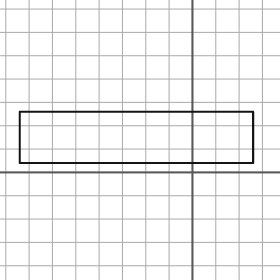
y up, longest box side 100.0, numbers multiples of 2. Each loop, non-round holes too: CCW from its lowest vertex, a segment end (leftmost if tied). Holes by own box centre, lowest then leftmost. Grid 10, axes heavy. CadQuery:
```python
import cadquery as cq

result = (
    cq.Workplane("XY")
    .moveTo(-74.0, 4.0)
    .lineTo(26.0, 4.0)
    .lineTo(26.0, 26.0)
    .lineTo(-74.0, 26.0)
    .close()
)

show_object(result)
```